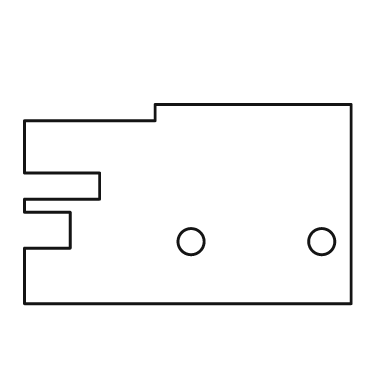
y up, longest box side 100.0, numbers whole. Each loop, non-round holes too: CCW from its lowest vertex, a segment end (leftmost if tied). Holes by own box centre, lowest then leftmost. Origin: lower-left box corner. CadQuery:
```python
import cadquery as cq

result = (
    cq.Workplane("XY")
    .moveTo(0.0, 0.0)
    .lineTo(100.0, 0.0)
    .lineTo(100.0, 61.0)
    .lineTo(40.0, 61.0)
    .lineTo(40.0, 56.0)
    .lineTo(0.0, 56.0)
    .lineTo(0.0, 40.0)
    .lineTo(23.0, 40.0)
    .lineTo(23.0, 32.0)
    .lineTo(0.0, 32.0)
    .lineTo(0.0, 28.0)
    .lineTo(14.0, 28.0)
    .lineTo(14.0, 17.0)
    .lineTo(0.0, 17.0)
    .close()
    .moveTo(51.0, 19.0)
    .circle(4.0)
    .moveTo(91.0, 19.0)
    .circle(4.0)
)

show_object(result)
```